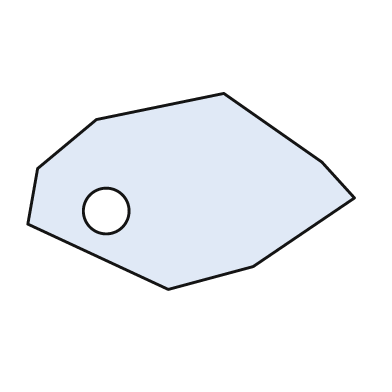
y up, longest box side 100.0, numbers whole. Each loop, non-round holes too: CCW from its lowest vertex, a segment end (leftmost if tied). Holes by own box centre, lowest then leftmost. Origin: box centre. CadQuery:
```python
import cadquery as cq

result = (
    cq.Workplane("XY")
    .moveTo(-7.0, -30.0)
    .lineTo(19.0, -23.0)
    .lineTo(50.0, -2.0)
    .lineTo(40.0, 9.0)
    .lineTo(10.0, 30.0)
    .lineTo(-29.0, 22.0)
    .lineTo(-47.0, 7.0)
    .lineTo(-50.0, -10.0)
    .close()
    .moveTo(-26.0, -6.0)
    .circle(7.0)
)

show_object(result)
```